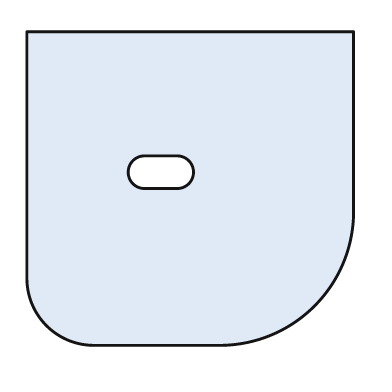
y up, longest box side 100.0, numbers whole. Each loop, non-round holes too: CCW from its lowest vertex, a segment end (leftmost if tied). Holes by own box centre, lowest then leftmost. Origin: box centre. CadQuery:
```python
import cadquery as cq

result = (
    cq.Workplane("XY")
    .moveTo(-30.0, -48.0)
    .lineTo(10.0, -48.0)
    .threePointArc((38.0, -36.0), (50.0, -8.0))
    .lineTo(50.0, 48.0)
    .lineTo(-50.0, 48.0)
    .lineTo(-50.0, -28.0)
    .threePointArc((-44.0, -42.0), (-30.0, -48.0))
    .close()
    .moveTo(-14.0, 0.0)
    .lineTo(-4.0, 0.0)
    .threePointArc((1.0, 5.0), (-4.0, 10.0))
    .lineTo(-14.0, 10.0)
    .threePointArc((-19.0, 5.0), (-14.0, 0.0))
    .close()
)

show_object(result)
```